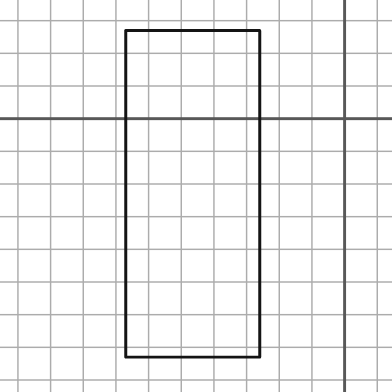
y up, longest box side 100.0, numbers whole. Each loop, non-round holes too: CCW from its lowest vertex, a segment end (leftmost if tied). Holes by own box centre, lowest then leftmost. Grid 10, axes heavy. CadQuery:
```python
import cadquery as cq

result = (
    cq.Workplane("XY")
    .moveTo(-67.0, -73.0)
    .lineTo(-26.0, -73.0)
    .lineTo(-26.0, 27.0)
    .lineTo(-67.0, 27.0)
    .close()
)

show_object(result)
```